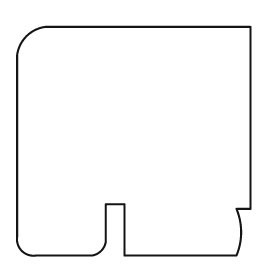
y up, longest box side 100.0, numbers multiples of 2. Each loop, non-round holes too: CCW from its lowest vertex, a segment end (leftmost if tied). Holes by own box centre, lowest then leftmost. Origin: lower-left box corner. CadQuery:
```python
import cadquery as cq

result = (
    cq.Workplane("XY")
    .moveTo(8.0, 0.0)
    .lineTo(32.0, 0.0)
    .threePointArc((36.0, 2.0), (38.0, 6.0))
    .lineTo(38.0, 22.0)
    .lineTo(46.0, 22.0)
    .lineTo(46.0, 0.0)
    .lineTo(94.0, 0.0)
    .threePointArc((96.0, 10.0), (94.0, 20.0))
    .lineTo(100.0, 20.0)
    .lineTo(100.0, 98.0)
    .lineTo(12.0, 98.0)
    .threePointArc((4.0, 94.0), (0.0, 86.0))
    .lineTo(0.0, 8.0)
    .threePointArc((2.0, 2.0), (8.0, 0.0))
    .close()
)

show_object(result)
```